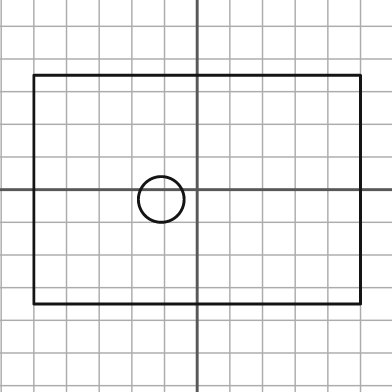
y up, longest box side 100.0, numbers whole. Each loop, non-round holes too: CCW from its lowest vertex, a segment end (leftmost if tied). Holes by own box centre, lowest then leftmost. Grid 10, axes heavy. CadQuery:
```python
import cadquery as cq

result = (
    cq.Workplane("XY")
    .moveTo(-50.0, -35.0)
    .lineTo(50.0, -35.0)
    .lineTo(50.0, 35.0)
    .lineTo(-50.0, 35.0)
    .close()
    .moveTo(-11.0, -3.0)
    .circle(7.0)
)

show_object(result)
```